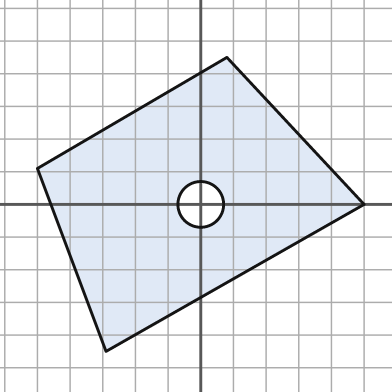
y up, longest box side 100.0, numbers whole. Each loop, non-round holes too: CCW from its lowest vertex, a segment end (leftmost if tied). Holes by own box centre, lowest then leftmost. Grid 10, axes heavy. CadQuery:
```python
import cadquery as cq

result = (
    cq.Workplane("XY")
    .moveTo(-29.0, -45.0)
    .lineTo(50.0, 0.0)
    .lineTo(8.0, 45.0)
    .lineTo(-50.0, 11.0)
    .close()
    .moveTo(0.0, 0.0)
    .circle(7.0)
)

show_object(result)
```